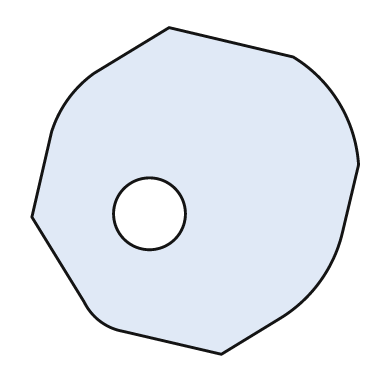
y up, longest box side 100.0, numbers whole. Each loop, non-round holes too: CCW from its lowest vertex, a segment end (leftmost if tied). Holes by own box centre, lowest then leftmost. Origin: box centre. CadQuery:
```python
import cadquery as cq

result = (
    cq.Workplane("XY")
    .moveTo(8.0, -50.0)
    .lineTo(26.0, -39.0)
    .threePointArc((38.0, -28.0), (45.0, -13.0))
    .lineTo(50.0, 8.0)
    .threePointArc((44.0, 27.0), (30.0, 41.0))
    .lineTo(-8.0, 50.0)
    .lineTo(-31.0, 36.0)
    .threePointArc((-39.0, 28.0), (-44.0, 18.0))
    .lineTo(-50.0, -8.0)
    .lineTo(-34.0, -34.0)
    .threePointArc((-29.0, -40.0), (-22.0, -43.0))
    .close()
    .moveTo(-14.0, -7.0)
    .circle(11.0)
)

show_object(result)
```